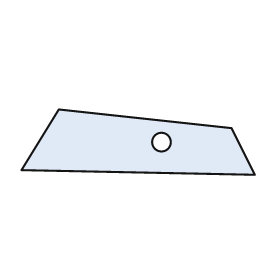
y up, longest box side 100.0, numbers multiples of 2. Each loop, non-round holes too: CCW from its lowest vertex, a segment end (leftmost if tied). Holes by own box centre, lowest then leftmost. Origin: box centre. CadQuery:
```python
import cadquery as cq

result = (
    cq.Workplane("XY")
    .moveTo(50.0, -14.0)
    .lineTo(40.0, 6.0)
    .lineTo(-34.0, 14.0)
    .lineTo(-50.0, -12.0)
    .close()
    .moveTo(10.0, 0.0)
    .circle(4.0)
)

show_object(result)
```